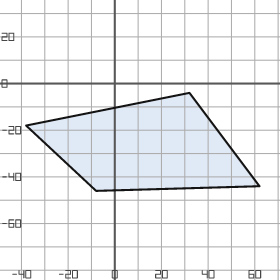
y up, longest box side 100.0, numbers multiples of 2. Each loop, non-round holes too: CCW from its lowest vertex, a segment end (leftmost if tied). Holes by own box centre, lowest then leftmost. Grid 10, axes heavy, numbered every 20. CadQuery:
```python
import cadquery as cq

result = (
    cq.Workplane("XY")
    .moveTo(-8.0, -46.0)
    .lineTo(62.0, -44.0)
    .lineTo(32.0, -4.0)
    .lineTo(-38.0, -18.0)
    .close()
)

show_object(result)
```